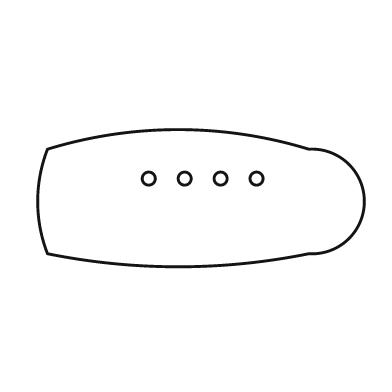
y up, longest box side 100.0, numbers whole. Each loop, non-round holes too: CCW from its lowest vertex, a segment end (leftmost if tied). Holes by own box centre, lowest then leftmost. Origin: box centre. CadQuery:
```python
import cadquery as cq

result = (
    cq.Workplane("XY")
    .moveTo(-47.0, -17.0)
    .threePointArc((-7.0, -21.0), (33.0, -17.0))
    .threePointArc((50.0, -1.0), (33.0, 15.0))
    .threePointArc((-7.0, 21.0), (-47.0, 15.0))
    .threePointArc((-50.0, -1.0), (-47.0, -17.0))
    .close()
    .moveTo(-16.0, 6.0)
    .circle(2.0)
    .moveTo(-5.0, 6.0)
    .circle(2.0)
    .moveTo(6.0, 6.0)
    .circle(2.0)
    .moveTo(17.0, 6.0)
    .circle(2.0)
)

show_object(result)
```